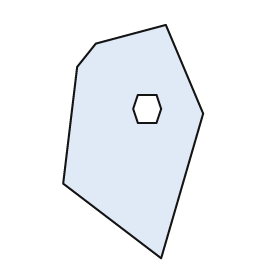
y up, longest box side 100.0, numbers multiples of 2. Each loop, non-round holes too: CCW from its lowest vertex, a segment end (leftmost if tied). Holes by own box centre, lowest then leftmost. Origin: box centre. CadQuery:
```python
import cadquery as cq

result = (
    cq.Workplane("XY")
    .moveTo(12.0, -50.0)
    .lineTo(30.0, 12.0)
    .lineTo(14.0, 50.0)
    .lineTo(-16.0, 42.0)
    .lineTo(-24.0, 32.0)
    .lineTo(-30.0, -18.0)
    .close()
    .moveTo(2.0, 8.0)
    .lineTo(10.0, 8.0)
    .lineTo(12.0, 14.0)
    .lineTo(10.0, 20.0)
    .lineTo(2.0, 20.0)
    .lineTo(0.0, 14.0)
    .close()
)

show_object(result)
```